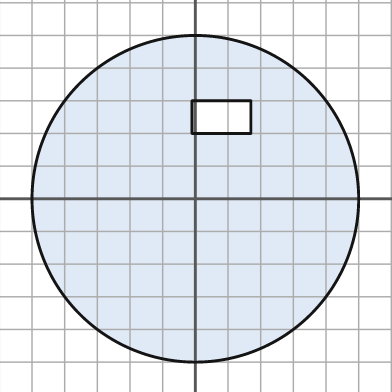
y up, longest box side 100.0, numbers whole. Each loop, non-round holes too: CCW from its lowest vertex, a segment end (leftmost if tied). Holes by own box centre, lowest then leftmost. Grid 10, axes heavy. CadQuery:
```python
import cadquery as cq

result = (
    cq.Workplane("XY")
    .moveTo(0.0, 0.0)
    .circle(50.0)
    .moveTo(-1.0, 20.0)
    .lineTo(17.0, 20.0)
    .lineTo(17.0, 30.0)
    .lineTo(-1.0, 30.0)
    .close()
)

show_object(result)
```